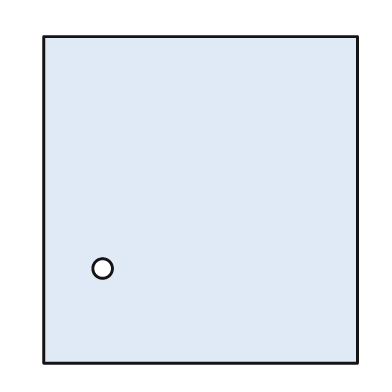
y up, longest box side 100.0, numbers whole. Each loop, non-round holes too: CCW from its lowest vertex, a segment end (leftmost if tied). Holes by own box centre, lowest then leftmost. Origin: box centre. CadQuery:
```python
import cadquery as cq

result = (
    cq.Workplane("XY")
    .moveTo(-48.0, -50.0)
    .lineTo(48.0, -50.0)
    .lineTo(48.0, 50.0)
    .lineTo(-48.0, 50.0)
    .close()
    .moveTo(-30.0, -21.0)
    .circle(3.0)
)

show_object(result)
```